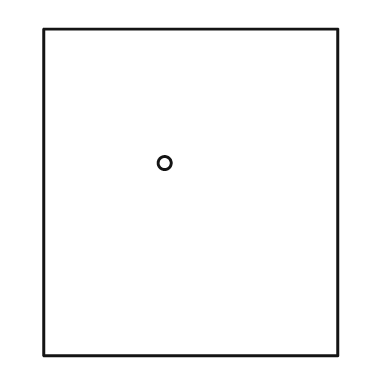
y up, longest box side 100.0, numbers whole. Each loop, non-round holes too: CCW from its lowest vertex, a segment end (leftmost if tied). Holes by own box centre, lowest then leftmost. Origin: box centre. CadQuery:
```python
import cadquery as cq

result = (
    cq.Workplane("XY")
    .moveTo(-45.0, -50.0)
    .lineTo(45.0, -50.0)
    .lineTo(45.0, 50.0)
    .lineTo(-45.0, 50.0)
    .close()
    .moveTo(-8.0, 9.0)
    .circle(2.0)
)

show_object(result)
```